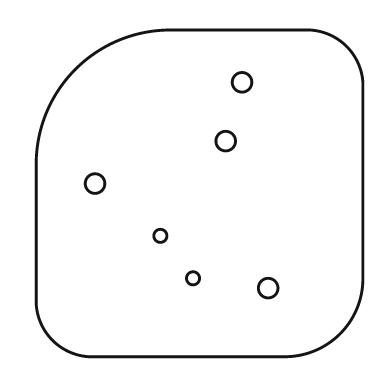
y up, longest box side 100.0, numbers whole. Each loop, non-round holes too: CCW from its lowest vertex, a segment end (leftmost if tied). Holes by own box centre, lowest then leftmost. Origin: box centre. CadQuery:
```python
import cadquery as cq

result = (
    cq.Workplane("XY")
    .moveTo(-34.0, -50.0)
    .lineTo(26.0, -50.0)
    .threePointArc((43.0, -43.0), (50.0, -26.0))
    .lineTo(50.0, 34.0)
    .threePointArc((45.0, 45.0), (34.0, 50.0))
    .lineTo(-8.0, 50.0)
    .threePointArc((-38.0, 38.0), (-50.0, 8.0))
    .lineTo(-50.0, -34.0)
    .threePointArc((-45.0, -45.0), (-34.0, -50.0))
    .close()
    .moveTo(21.0, -29.0)
    .circle(3.0)
    .moveTo(-2.0, -26.0)
    .circle(2.0)
    .moveTo(-12.0, -13.0)
    .circle(2.0)
    .moveTo(-32.0, 3.0)
    .circle(3.0)
    .moveTo(8.0, 16.0)
    .circle(3.0)
    .moveTo(13.0, 34.0)
    .circle(3.0)
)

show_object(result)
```